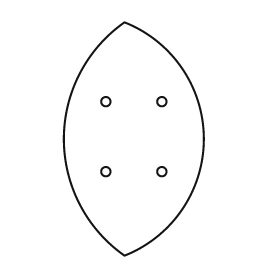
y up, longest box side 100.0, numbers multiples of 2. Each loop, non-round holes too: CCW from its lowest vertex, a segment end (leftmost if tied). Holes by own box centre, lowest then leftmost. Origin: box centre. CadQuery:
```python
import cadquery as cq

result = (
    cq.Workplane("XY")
    .moveTo(-4.0, -50.0)
    .threePointArc((30.0, 0.0), (-4.0, 50.0))
    .threePointArc((-30.0, 0.0), (-4.0, -50.0))
    .close()
    .moveTo(-12.0, -14.0)
    .circle(2.0)
    .moveTo(12.0, -14.0)
    .circle(2.0)
    .moveTo(-12.0, 16.0)
    .circle(2.0)
    .moveTo(12.0, 16.0)
    .circle(2.0)
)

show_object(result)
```